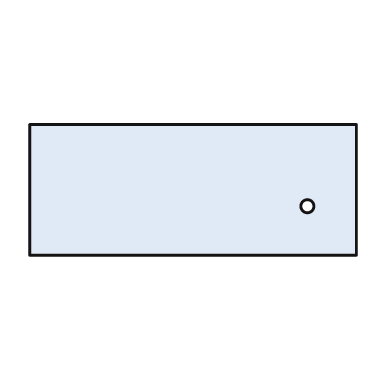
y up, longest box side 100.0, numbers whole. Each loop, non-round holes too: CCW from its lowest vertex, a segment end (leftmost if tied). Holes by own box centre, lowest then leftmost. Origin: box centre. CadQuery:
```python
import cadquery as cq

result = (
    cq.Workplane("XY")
    .moveTo(-50.0, -20.0)
    .lineTo(50.0, -20.0)
    .lineTo(50.0, 20.0)
    .lineTo(-50.0, 20.0)
    .close()
    .moveTo(35.0, -5.0)
    .circle(2.0)
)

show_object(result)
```